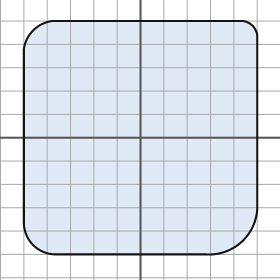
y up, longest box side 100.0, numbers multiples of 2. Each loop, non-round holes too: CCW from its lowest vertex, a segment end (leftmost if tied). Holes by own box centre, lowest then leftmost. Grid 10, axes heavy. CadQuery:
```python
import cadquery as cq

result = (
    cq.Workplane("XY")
    .moveTo(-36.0, -50.0)
    .lineTo(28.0, -50.0)
    .threePointArc((44.0, -44.0), (50.0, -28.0))
    .lineTo(50.0, 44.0)
    .threePointArc((48.0, 48.0), (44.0, 50.0))
    .lineTo(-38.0, 50.0)
    .threePointArc((-46.0, 46.0), (-50.0, 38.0))
    .lineTo(-50.0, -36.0)
    .threePointArc((-46.0, -46.0), (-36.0, -50.0))
    .close()
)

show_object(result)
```